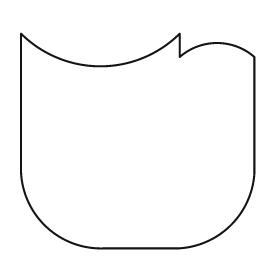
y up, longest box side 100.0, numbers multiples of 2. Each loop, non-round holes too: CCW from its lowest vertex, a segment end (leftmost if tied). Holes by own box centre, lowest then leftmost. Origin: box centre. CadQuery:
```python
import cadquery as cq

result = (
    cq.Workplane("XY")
    .moveTo(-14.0, -46.0)
    .lineTo(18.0, -46.0)
    .threePointArc((40.0, -36.0), (50.0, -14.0))
    .lineTo(50.0, 36.0)
    .threePointArc((34.0, 42.0), (18.0, 36.0))
    .lineTo(18.0, 46.0)
    .threePointArc((-16.0, 32.0), (-50.0, 46.0))
    .lineTo(-50.0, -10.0)
    .threePointArc((-40.0, -36.0), (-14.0, -46.0))
    .close()
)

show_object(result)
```